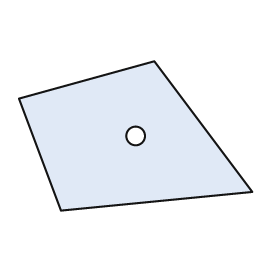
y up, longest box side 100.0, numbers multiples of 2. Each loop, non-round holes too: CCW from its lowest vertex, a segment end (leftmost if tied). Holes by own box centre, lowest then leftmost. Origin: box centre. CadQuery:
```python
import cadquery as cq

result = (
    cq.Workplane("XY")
    .moveTo(-32.0, -32.0)
    .lineTo(50.0, -24.0)
    .lineTo(8.0, 32.0)
    .lineTo(-50.0, 16.0)
    .close()
    .moveTo(0.0, 0.0)
    .circle(4.0)
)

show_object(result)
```